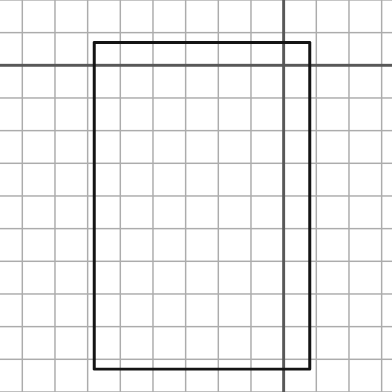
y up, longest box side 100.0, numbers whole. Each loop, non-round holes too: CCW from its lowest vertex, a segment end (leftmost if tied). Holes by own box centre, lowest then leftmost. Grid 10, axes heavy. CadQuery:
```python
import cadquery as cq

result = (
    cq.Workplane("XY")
    .moveTo(-58.0, -93.0)
    .lineTo(8.0, -93.0)
    .lineTo(8.0, 7.0)
    .lineTo(-58.0, 7.0)
    .close()
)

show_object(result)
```